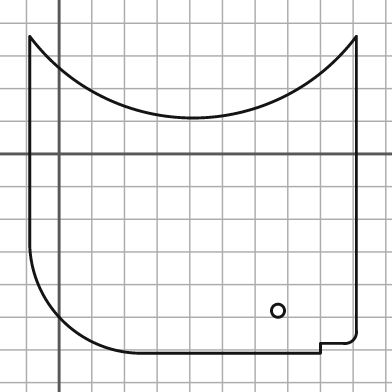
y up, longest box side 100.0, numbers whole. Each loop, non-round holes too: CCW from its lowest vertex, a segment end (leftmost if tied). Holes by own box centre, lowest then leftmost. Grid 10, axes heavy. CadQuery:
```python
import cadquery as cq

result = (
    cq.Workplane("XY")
    .moveTo(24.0, -61.0)
    .lineTo(80.0, -61.0)
    .lineTo(80.0, -58.0)
    .lineTo(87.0, -58.0)
    .threePointArc((90.0, -57.0), (91.0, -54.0))
    .lineTo(91.0, 36.0)
    .threePointArc((41.0, 11.0), (-9.0, 36.0))
    .lineTo(-9.0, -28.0)
    .threePointArc((1.0, -51.0), (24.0, -61.0))
    .close()
    .moveTo(67.0, -48.0)
    .circle(2.0)
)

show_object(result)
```